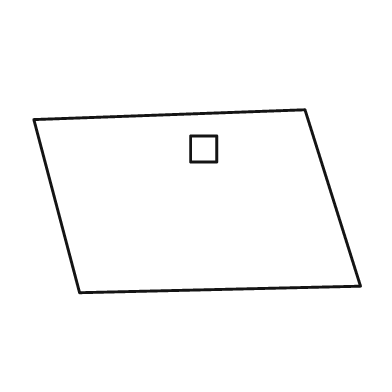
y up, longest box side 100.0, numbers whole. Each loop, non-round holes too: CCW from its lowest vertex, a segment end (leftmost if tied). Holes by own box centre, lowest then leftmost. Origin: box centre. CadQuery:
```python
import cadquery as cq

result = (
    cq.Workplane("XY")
    .moveTo(-36.0, -28.0)
    .lineTo(50.0, -26.0)
    .lineTo(33.0, 28.0)
    .lineTo(-50.0, 25.0)
    .close()
    .moveTo(-2.0, 12.0)
    .lineTo(6.0, 12.0)
    .lineTo(6.0, 20.0)
    .lineTo(-2.0, 20.0)
    .close()
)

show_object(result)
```